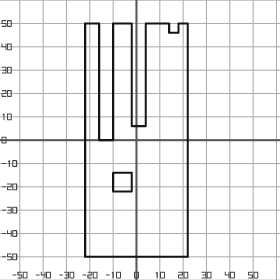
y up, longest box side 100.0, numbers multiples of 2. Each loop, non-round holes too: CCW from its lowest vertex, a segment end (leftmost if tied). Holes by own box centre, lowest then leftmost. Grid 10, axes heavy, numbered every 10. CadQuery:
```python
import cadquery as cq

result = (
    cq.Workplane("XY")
    .moveTo(-22.0, -50.0)
    .lineTo(22.0, -50.0)
    .lineTo(22.0, 50.0)
    .lineTo(18.0, 50.0)
    .lineTo(18.0, 46.0)
    .lineTo(14.0, 46.0)
    .lineTo(14.0, 50.0)
    .lineTo(4.0, 50.0)
    .lineTo(4.0, 6.0)
    .lineTo(-2.0, 6.0)
    .lineTo(-2.0, 50.0)
    .lineTo(-10.0, 50.0)
    .lineTo(-10.0, 0.0)
    .lineTo(-16.0, 0.0)
    .lineTo(-16.0, 50.0)
    .lineTo(-22.0, 50.0)
    .close()
    .moveTo(-10.0, -22.0)
    .lineTo(-2.0, -22.0)
    .lineTo(-2.0, -14.0)
    .lineTo(-10.0, -14.0)
    .close()
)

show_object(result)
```